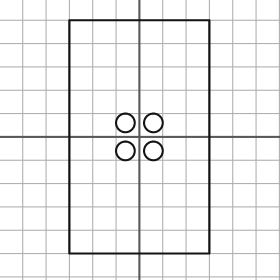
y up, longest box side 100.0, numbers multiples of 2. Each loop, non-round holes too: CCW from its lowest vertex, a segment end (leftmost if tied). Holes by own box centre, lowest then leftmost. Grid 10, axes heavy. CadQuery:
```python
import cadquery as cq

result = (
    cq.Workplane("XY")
    .moveTo(-30.0, -50.0)
    .lineTo(30.0, -50.0)
    .lineTo(30.0, 50.0)
    .lineTo(-30.0, 50.0)
    .close()
    .moveTo(-6.0, -6.0)
    .circle(4.0)
    .moveTo(6.0, -6.0)
    .circle(4.0)
    .moveTo(-6.0, 6.0)
    .circle(4.0)
    .moveTo(6.0, 6.0)
    .circle(4.0)
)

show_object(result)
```